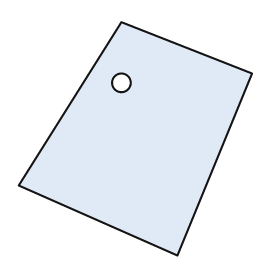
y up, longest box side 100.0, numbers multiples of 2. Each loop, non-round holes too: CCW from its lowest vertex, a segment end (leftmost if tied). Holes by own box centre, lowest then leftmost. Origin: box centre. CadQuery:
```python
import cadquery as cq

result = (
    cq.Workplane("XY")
    .moveTo(18.0, -50.0)
    .lineTo(50.0, 28.0)
    .lineTo(-6.0, 50.0)
    .lineTo(-50.0, -20.0)
    .close()
    .moveTo(-6.0, 24.0)
    .circle(4.0)
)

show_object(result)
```